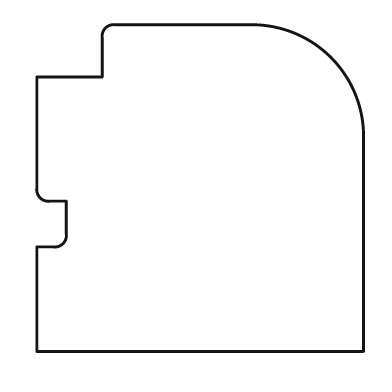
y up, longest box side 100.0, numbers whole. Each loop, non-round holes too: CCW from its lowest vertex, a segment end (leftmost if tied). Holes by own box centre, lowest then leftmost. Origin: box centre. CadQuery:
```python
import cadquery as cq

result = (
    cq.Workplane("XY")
    .moveTo(-50.0, -50.0)
    .lineTo(50.0, -50.0)
    .lineTo(50.0, 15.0)
    .threePointArc((40.0, 40.0), (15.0, 50.0))
    .lineTo(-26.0, 50.0)
    .threePointArc((-29.0, 49.0), (-30.0, 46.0))
    .lineTo(-30.0, 34.0)
    .lineTo(-50.0, 34.0)
    .lineTo(-50.0, 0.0)
    .threePointArc((-49.0, -3.0), (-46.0, -4.0))
    .lineTo(-41.0, -4.0)
    .lineTo(-41.0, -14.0)
    .threePointArc((-42.0, -17.0), (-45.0, -18.0))
    .lineTo(-50.0, -18.0)
    .close()
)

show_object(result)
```